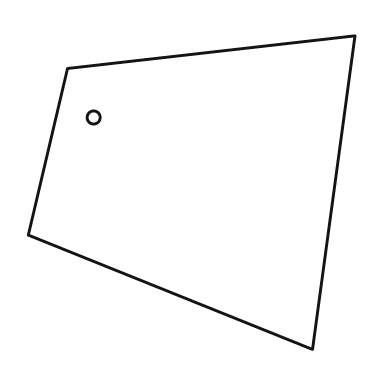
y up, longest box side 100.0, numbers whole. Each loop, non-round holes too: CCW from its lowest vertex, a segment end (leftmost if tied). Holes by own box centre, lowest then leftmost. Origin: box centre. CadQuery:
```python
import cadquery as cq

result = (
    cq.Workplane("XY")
    .moveTo(37.0, -48.0)
    .lineTo(50.0, 48.0)
    .lineTo(-38.0, 38.0)
    .lineTo(-50.0, -13.0)
    .close()
    .moveTo(-30.0, 23.0)
    .circle(2.0)
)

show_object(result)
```